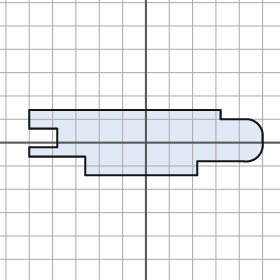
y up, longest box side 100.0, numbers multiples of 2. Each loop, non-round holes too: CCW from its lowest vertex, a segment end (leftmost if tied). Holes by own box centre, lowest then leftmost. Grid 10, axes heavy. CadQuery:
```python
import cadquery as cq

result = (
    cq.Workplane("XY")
    .moveTo(-26.0, -14.0)
    .lineTo(22.0, -14.0)
    .lineTo(22.0, -8.0)
    .lineTo(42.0, -8.0)
    .threePointArc((48.0, -6.0), (50.0, 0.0))
    .lineTo(50.0, 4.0)
    .threePointArc((48.0, 8.0), (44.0, 10.0))
    .lineTo(32.0, 10.0)
    .lineTo(32.0, 14.0)
    .lineTo(-50.0, 14.0)
    .lineTo(-50.0, 6.0)
    .lineTo(-38.0, 6.0)
    .lineTo(-38.0, -2.0)
    .lineTo(-50.0, -2.0)
    .lineTo(-50.0, -6.0)
    .lineTo(-26.0, -6.0)
    .close()
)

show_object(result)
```